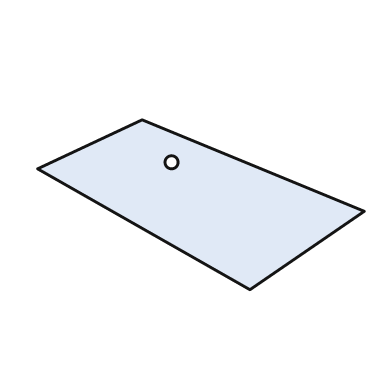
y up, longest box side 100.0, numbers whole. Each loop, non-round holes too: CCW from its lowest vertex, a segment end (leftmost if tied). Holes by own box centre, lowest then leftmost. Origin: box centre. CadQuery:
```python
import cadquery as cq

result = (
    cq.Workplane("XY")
    .moveTo(15.0, -26.0)
    .lineTo(50.0, -2.0)
    .lineTo(-18.0, 26.0)
    .lineTo(-50.0, 11.0)
    .close()
    .moveTo(-9.0, 13.0)
    .circle(2.0)
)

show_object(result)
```